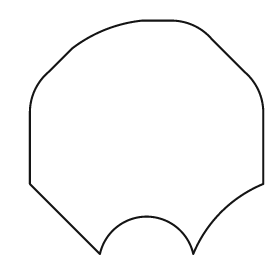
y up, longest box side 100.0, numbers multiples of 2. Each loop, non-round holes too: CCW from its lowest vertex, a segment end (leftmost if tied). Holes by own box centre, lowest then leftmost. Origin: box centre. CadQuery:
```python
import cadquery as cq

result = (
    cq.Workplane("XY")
    .moveTo(-20.0, -50.0)
    .threePointArc((0.0, -34.0), (20.0, -50.0))
    .threePointArc((32.0, -32.0), (50.0, -20.0))
    .lineTo(50.0, 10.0)
    .threePointArc((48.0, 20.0), (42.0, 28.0))
    .lineTo(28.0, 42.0)
    .threePointArc((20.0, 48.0), (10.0, 50.0))
    .lineTo(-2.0, 50.0)
    .threePointArc((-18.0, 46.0), (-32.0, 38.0))
    .lineTo(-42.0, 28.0)
    .threePointArc((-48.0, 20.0), (-50.0, 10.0))
    .lineTo(-50.0, -20.0)
    .close()
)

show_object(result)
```